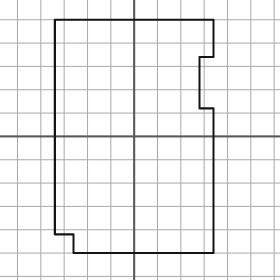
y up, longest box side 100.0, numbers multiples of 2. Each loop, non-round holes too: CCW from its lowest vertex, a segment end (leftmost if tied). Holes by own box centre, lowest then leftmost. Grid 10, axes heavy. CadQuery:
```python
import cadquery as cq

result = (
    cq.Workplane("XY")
    .moveTo(-26.0, -50.0)
    .lineTo(34.0, -50.0)
    .lineTo(34.0, 12.0)
    .lineTo(28.0, 12.0)
    .lineTo(28.0, 34.0)
    .lineTo(34.0, 34.0)
    .lineTo(34.0, 50.0)
    .lineTo(-34.0, 50.0)
    .lineTo(-34.0, -42.0)
    .lineTo(-26.0, -42.0)
    .close()
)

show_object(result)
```